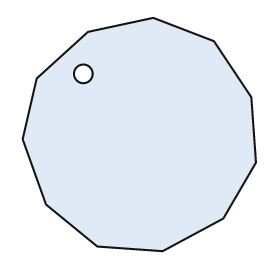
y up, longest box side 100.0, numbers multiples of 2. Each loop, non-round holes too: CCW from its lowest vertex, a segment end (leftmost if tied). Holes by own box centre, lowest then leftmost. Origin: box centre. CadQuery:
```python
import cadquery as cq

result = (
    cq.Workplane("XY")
    .moveTo(10.0, -50.0)
    .lineTo(36.0, -36.0)
    .lineTo(50.0, -12.0)
    .lineTo(48.0, 16.0)
    .lineTo(32.0, 40.0)
    .lineTo(6.0, 50.0)
    .lineTo(-22.0, 44.0)
    .lineTo(-44.0, 24.0)
    .lineTo(-50.0, -2.0)
    .lineTo(-40.0, -30.0)
    .lineTo(-18.0, -48.0)
    .close()
    .moveTo(-24.0, 26.0)
    .circle(4.0)
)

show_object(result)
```